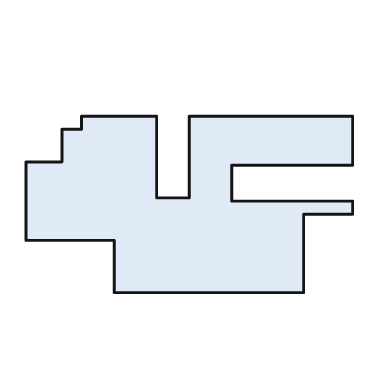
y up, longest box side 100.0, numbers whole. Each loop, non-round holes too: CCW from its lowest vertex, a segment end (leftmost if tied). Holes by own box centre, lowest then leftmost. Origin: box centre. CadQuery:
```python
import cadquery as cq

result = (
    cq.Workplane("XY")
    .moveTo(-23.0, -27.0)
    .lineTo(35.0, -27.0)
    .lineTo(35.0, -3.0)
    .lineTo(50.0, -3.0)
    .lineTo(50.0, 1.0)
    .lineTo(13.0, 1.0)
    .lineTo(13.0, 12.0)
    .lineTo(50.0, 12.0)
    .lineTo(50.0, 27.0)
    .lineTo(0.0, 27.0)
    .lineTo(0.0, 2.0)
    .lineTo(-10.0, 2.0)
    .lineTo(-10.0, 27.0)
    .lineTo(-33.0, 27.0)
    .lineTo(-33.0, 23.0)
    .lineTo(-39.0, 23.0)
    .lineTo(-39.0, 13.0)
    .lineTo(-50.0, 13.0)
    .lineTo(-50.0, -11.0)
    .lineTo(-23.0, -11.0)
    .close()
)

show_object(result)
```